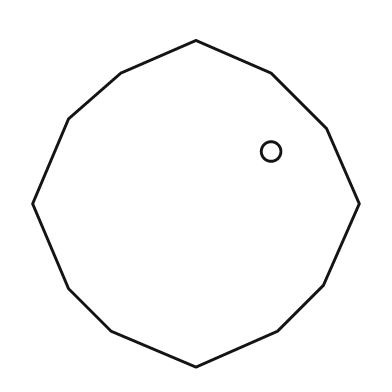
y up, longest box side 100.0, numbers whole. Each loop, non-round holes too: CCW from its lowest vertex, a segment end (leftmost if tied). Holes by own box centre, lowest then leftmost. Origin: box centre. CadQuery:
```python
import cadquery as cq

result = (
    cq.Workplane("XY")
    .moveTo(0.0, -50.0)
    .lineTo(25.0, -39.0)
    .lineTo(39.0, -25.0)
    .lineTo(50.0, 0.0)
    .lineTo(40.0, 23.0)
    .lineTo(23.0, 40.0)
    .lineTo(0.0, 50.0)
    .lineTo(-23.0, 40.0)
    .lineTo(-39.0, 26.0)
    .lineTo(-50.0, 0.0)
    .lineTo(-39.0, -26.0)
    .lineTo(-26.0, -39.0)
    .close()
    .moveTo(23.0, 16.0)
    .circle(3.0)
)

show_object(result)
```